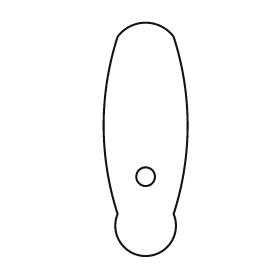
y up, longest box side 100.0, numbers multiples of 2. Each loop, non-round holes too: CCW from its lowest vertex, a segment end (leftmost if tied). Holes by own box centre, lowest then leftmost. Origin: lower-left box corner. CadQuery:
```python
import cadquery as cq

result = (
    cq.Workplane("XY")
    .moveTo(6.0, 18.0)
    .threePointArc((18.0, 0.0), (30.0, 18.0))
    .threePointArc((36.0, 56.0), (30.0, 94.0))
    .threePointArc((18.0, 100.0), (6.0, 94.0))
    .threePointArc((0.0, 56.0), (6.0, 18.0))
    .close()
    .moveTo(18.0, 34.0)
    .circle(4.0)
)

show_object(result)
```